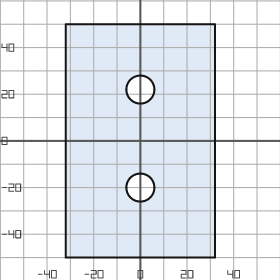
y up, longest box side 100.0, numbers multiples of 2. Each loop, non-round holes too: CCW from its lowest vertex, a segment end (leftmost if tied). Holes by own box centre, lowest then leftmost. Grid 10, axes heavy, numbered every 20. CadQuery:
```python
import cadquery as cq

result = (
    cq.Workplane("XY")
    .moveTo(-32.0, -50.0)
    .lineTo(32.0, -50.0)
    .lineTo(32.0, 50.0)
    .lineTo(-32.0, 50.0)
    .close()
    .moveTo(0.0, -20.0)
    .circle(6.0)
    .moveTo(0.0, 22.0)
    .circle(6.0)
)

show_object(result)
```